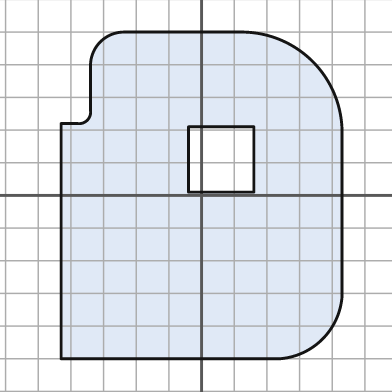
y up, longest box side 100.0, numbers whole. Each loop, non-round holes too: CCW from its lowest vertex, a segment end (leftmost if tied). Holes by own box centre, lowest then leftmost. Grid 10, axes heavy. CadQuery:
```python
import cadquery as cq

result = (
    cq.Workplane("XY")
    .moveTo(-43.0, -50.0)
    .lineTo(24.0, -50.0)
    .threePointArc((37.0, -44.0), (43.0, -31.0))
    .lineTo(43.0, 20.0)
    .threePointArc((34.0, 41.0), (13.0, 50.0))
    .lineTo(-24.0, 50.0)
    .threePointArc((-31.0, 47.0), (-34.0, 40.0))
    .lineTo(-34.0, 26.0)
    .threePointArc((-35.0, 23.0), (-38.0, 22.0))
    .lineTo(-43.0, 22.0)
    .close()
    .moveTo(-4.0, 1.0)
    .lineTo(16.0, 1.0)
    .lineTo(16.0, 21.0)
    .lineTo(-4.0, 21.0)
    .close()
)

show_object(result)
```